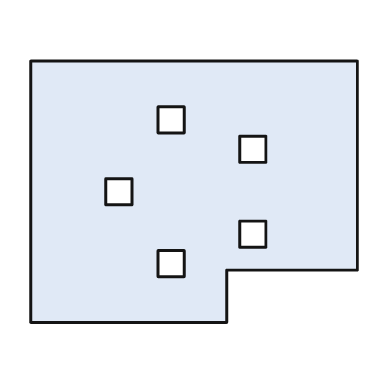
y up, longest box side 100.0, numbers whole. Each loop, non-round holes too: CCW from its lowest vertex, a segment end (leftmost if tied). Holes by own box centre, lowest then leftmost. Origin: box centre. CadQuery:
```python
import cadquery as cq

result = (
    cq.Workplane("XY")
    .moveTo(-50.0, -40.0)
    .lineTo(10.0, -40.0)
    .lineTo(10.0, -24.0)
    .lineTo(50.0, -24.0)
    .lineTo(50.0, 40.0)
    .lineTo(-50.0, 40.0)
    .close()
    .moveTo(-11.0, -26.0)
    .lineTo(-3.0, -26.0)
    .lineTo(-3.0, -18.0)
    .lineTo(-11.0, -18.0)
    .close()
    .moveTo(14.0, -17.0)
    .lineTo(22.0, -17.0)
    .lineTo(22.0, -9.0)
    .lineTo(14.0, -9.0)
    .close()
    .moveTo(-27.0, -4.0)
    .lineTo(-19.0, -4.0)
    .lineTo(-19.0, 4.0)
    .lineTo(-27.0, 4.0)
    .close()
    .moveTo(14.0, 9.0)
    .lineTo(22.0, 9.0)
    .lineTo(22.0, 17.0)
    .lineTo(14.0, 17.0)
    .close()
    .moveTo(-11.0, 18.0)
    .lineTo(-3.0, 18.0)
    .lineTo(-3.0, 26.0)
    .lineTo(-11.0, 26.0)
    .close()
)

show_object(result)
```